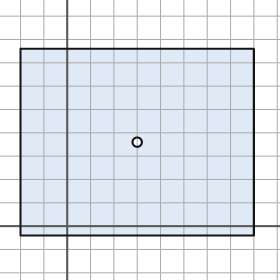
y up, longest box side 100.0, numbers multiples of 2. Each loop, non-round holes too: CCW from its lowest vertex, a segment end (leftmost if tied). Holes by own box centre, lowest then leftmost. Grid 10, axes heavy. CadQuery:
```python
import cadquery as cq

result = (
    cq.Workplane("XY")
    .moveTo(-20.0, -4.0)
    .lineTo(80.0, -4.0)
    .lineTo(80.0, 76.0)
    .lineTo(-20.0, 76.0)
    .close()
    .moveTo(30.0, 36.0)
    .circle(2.0)
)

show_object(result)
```